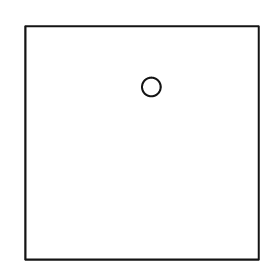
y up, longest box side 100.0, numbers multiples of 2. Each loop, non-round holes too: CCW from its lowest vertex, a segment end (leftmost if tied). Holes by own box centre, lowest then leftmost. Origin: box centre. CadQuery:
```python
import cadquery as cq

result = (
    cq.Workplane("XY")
    .moveTo(-50.0, -50.0)
    .lineTo(50.0, -50.0)
    .lineTo(50.0, 50.0)
    .lineTo(-50.0, 50.0)
    .close()
    .moveTo(4.0, 24.0)
    .circle(4.0)
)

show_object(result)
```